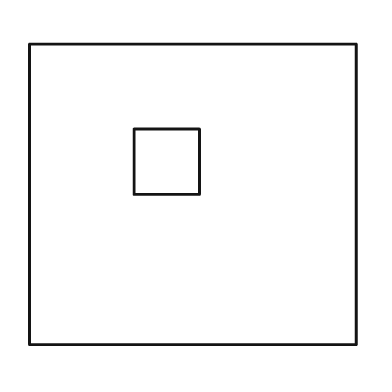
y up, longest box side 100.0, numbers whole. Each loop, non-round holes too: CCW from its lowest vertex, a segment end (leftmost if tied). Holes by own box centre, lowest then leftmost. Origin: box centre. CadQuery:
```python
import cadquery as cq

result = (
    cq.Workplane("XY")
    .moveTo(-50.0, -46.0)
    .lineTo(50.0, -46.0)
    .lineTo(50.0, 46.0)
    .lineTo(-50.0, 46.0)
    .close()
    .moveTo(-18.0, 0.0)
    .lineTo(2.0, 0.0)
    .lineTo(2.0, 20.0)
    .lineTo(-18.0, 20.0)
    .close()
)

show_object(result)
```